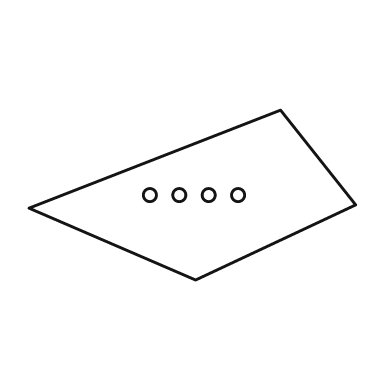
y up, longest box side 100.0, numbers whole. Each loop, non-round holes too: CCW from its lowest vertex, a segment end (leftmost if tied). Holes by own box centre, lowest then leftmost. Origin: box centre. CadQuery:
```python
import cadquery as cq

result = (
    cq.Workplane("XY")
    .moveTo(1.0, -26.0)
    .lineTo(50.0, -3.0)
    .lineTo(27.0, 26.0)
    .lineTo(-50.0, -4.0)
    .close()
    .moveTo(-13.0, 0.0)
    .circle(2.0)
    .moveTo(-4.0, 0.0)
    .circle(2.0)
    .moveTo(5.0, 0.0)
    .circle(2.0)
    .moveTo(14.0, 0.0)
    .circle(2.0)
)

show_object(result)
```